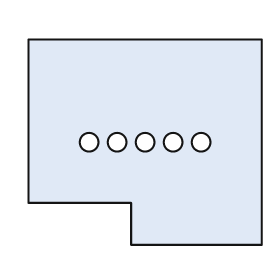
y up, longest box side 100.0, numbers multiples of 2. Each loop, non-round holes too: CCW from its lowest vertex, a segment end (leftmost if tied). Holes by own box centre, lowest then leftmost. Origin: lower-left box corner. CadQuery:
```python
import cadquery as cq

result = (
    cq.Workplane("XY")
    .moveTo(44.0, 0.0)
    .lineTo(100.0, 0.0)
    .lineTo(100.0, 88.0)
    .lineTo(0.0, 88.0)
    .lineTo(0.0, 18.0)
    .lineTo(44.0, 18.0)
    .close()
    .moveTo(26.0, 44.0)
    .circle(4.0)
    .moveTo(38.0, 44.0)
    .circle(4.0)
    .moveTo(50.0, 44.0)
    .circle(4.0)
    .moveTo(62.0, 44.0)
    .circle(4.0)
    .moveTo(74.0, 44.0)
    .circle(4.0)
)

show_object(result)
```